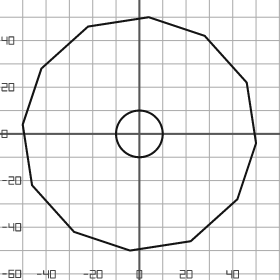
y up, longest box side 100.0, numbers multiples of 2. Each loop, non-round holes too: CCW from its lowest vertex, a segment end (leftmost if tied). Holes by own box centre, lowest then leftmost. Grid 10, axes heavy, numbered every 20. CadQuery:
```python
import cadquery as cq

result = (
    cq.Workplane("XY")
    .moveTo(-4.0, -50.0)
    .lineTo(22.0, -46.0)
    .lineTo(42.0, -28.0)
    .lineTo(50.0, -4.0)
    .lineTo(46.0, 22.0)
    .lineTo(28.0, 42.0)
    .lineTo(4.0, 50.0)
    .lineTo(-22.0, 46.0)
    .lineTo(-42.0, 28.0)
    .lineTo(-50.0, 4.0)
    .lineTo(-46.0, -22.0)
    .lineTo(-28.0, -42.0)
    .close()
    .moveTo(0.0, 0.0)
    .circle(10.0)
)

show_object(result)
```